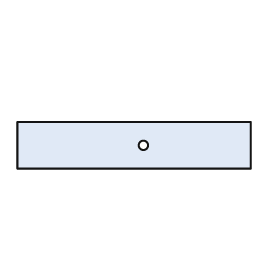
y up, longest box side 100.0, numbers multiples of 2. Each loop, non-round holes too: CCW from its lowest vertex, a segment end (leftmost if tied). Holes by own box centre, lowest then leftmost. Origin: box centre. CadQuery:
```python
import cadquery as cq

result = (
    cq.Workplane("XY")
    .moveTo(-50.0, -10.0)
    .lineTo(50.0, -10.0)
    .lineTo(50.0, 10.0)
    .lineTo(-50.0, 10.0)
    .close()
    .moveTo(4.0, 0.0)
    .circle(2.0)
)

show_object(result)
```